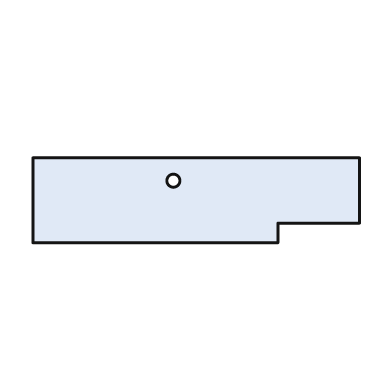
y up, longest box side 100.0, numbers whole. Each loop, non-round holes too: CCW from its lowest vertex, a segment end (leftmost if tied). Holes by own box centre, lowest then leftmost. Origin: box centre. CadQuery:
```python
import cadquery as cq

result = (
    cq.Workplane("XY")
    .moveTo(-50.0, -13.0)
    .lineTo(25.0, -13.0)
    .lineTo(25.0, -7.0)
    .lineTo(50.0, -7.0)
    .lineTo(50.0, 13.0)
    .lineTo(-50.0, 13.0)
    .close()
    .moveTo(-7.0, 6.0)
    .circle(2.0)
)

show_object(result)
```